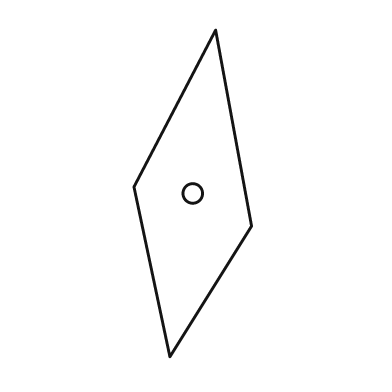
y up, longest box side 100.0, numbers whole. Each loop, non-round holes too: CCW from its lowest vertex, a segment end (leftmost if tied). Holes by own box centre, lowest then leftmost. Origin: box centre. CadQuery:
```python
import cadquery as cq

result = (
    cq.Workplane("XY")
    .moveTo(-7.0, -50.0)
    .lineTo(18.0, -10.0)
    .lineTo(7.0, 50.0)
    .lineTo(-18.0, 2.0)
    .close()
    .moveTo(0.0, 0.0)
    .circle(3.0)
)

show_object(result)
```